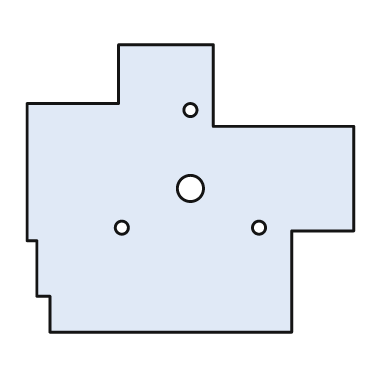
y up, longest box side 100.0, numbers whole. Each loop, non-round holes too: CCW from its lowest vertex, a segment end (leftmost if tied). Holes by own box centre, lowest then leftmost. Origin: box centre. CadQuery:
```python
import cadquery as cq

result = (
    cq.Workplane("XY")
    .moveTo(-43.0, -44.0)
    .lineTo(31.0, -44.0)
    .lineTo(31.0, -13.0)
    .lineTo(50.0, -13.0)
    .lineTo(50.0, 19.0)
    .lineTo(7.0, 19.0)
    .lineTo(7.0, 44.0)
    .lineTo(-22.0, 44.0)
    .lineTo(-22.0, 26.0)
    .lineTo(-50.0, 26.0)
    .lineTo(-50.0, -16.0)
    .lineTo(-47.0, -16.0)
    .lineTo(-47.0, -33.0)
    .lineTo(-43.0, -33.0)
    .close()
    .moveTo(-21.0, -12.0)
    .circle(2.0)
    .moveTo(21.0, -12.0)
    .circle(2.0)
    .moveTo(0.0, 0.0)
    .circle(4.0)
    .moveTo(0.0, 24.0)
    .circle(2.0)
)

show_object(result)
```